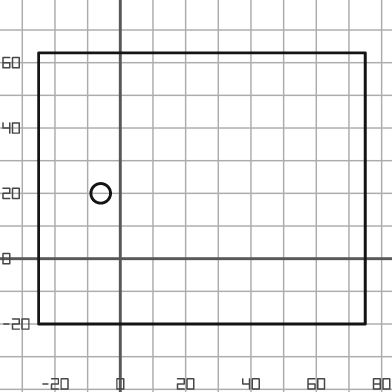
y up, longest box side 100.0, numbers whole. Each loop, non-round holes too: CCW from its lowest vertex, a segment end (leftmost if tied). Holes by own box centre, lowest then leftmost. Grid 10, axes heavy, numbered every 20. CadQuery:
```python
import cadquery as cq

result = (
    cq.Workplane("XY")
    .moveTo(-25.0, -20.0)
    .lineTo(75.0, -20.0)
    .lineTo(75.0, 63.0)
    .lineTo(-25.0, 63.0)
    .close()
    .moveTo(-6.0, 20.0)
    .circle(3.0)
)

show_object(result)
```